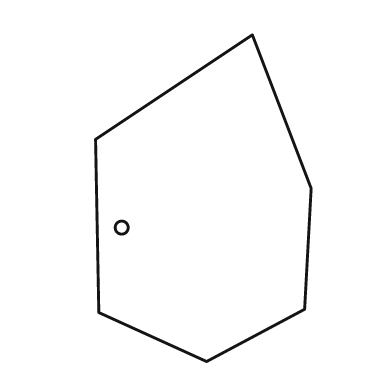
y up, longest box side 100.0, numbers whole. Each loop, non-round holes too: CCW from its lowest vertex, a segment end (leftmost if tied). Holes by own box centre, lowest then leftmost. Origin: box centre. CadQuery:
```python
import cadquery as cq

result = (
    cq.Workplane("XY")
    .moveTo(1.0, -50.0)
    .lineTo(31.0, -34.0)
    .lineTo(33.0, 3.0)
    .lineTo(15.0, 50.0)
    .lineTo(-33.0, 18.0)
    .lineTo(-32.0, -35.0)
    .close()
    .moveTo(-25.0, -9.0)
    .circle(2.0)
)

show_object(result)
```